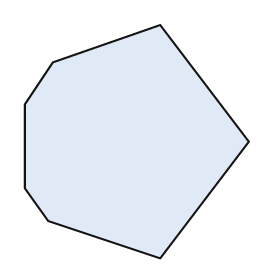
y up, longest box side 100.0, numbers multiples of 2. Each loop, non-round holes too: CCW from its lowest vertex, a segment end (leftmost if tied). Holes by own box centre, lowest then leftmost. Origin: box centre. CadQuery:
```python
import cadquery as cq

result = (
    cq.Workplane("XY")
    .moveTo(10.0, -50.0)
    .lineTo(48.0, 0.0)
    .lineTo(10.0, 50.0)
    .lineTo(-36.0, 34.0)
    .lineTo(-48.0, 16.0)
    .lineTo(-48.0, -20.0)
    .lineTo(-38.0, -34.0)
    .close()
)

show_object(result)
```